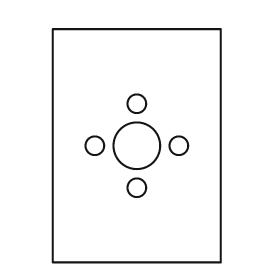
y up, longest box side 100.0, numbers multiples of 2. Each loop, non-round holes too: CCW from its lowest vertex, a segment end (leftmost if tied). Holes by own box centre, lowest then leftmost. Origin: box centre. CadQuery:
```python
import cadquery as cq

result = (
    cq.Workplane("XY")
    .moveTo(-36.0, -50.0)
    .lineTo(36.0, -50.0)
    .lineTo(36.0, 50.0)
    .lineTo(-36.0, 50.0)
    .close()
    .moveTo(0.0, -18.0)
    .circle(4.0)
    .moveTo(-18.0, 0.0)
    .circle(4.0)
    .moveTo(0.0, 0.0)
    .circle(10.0)
    .moveTo(18.0, 0.0)
    .circle(4.0)
    .moveTo(0.0, 18.0)
    .circle(4.0)
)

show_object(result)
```